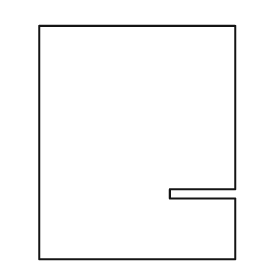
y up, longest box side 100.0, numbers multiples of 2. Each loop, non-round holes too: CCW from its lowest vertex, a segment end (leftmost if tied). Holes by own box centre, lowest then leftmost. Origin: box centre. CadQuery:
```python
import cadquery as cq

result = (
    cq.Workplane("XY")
    .moveTo(-42.0, -50.0)
    .lineTo(42.0, -50.0)
    .lineTo(42.0, -24.0)
    .lineTo(14.0, -24.0)
    .lineTo(14.0, -20.0)
    .lineTo(42.0, -20.0)
    .lineTo(42.0, 50.0)
    .lineTo(-42.0, 50.0)
    .close()
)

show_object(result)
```